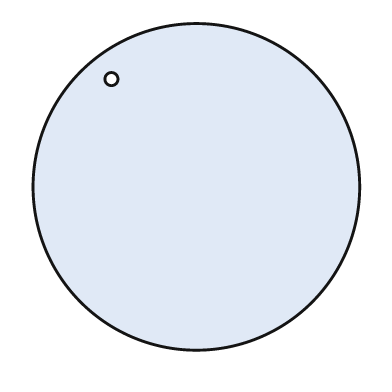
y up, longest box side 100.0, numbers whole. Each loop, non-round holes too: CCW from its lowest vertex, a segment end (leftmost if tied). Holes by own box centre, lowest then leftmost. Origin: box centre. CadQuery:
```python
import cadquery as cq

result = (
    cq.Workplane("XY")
    .moveTo(0.0, 0.0)
    .circle(50.0)
    .moveTo(-26.0, 33.0)
    .circle(2.0)
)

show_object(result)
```